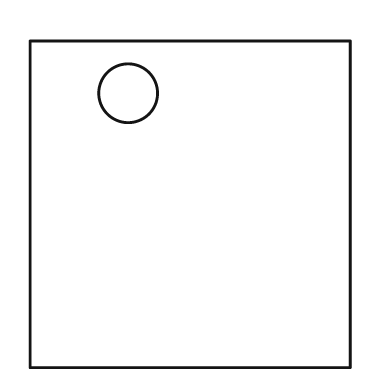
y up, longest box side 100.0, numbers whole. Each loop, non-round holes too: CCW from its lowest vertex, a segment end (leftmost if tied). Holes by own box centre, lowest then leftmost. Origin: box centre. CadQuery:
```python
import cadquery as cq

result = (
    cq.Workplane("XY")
    .moveTo(-49.0, -50.0)
    .lineTo(49.0, -50.0)
    .lineTo(49.0, 50.0)
    .lineTo(-49.0, 50.0)
    .close()
    .moveTo(-19.0, 34.0)
    .circle(9.0)
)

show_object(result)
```